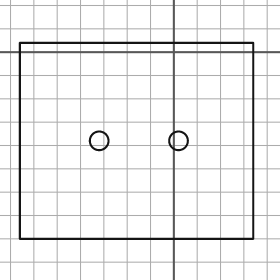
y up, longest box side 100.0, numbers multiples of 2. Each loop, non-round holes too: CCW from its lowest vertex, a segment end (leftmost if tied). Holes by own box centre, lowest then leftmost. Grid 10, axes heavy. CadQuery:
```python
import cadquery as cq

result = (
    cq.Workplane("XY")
    .moveTo(-66.0, -80.0)
    .lineTo(34.0, -80.0)
    .lineTo(34.0, 4.0)
    .lineTo(-66.0, 4.0)
    .close()
    .moveTo(-32.0, -38.0)
    .circle(4.0)
    .moveTo(2.0, -38.0)
    .circle(4.0)
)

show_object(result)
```